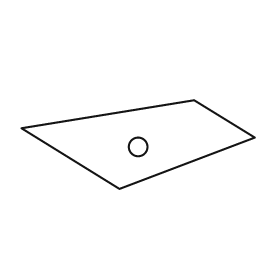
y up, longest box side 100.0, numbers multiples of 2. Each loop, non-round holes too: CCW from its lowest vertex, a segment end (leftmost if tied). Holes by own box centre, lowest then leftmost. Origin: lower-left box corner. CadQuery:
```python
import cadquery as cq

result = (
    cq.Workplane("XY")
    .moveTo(42.0, 0.0)
    .lineTo(100.0, 22.0)
    .lineTo(74.0, 38.0)
    .lineTo(0.0, 26.0)
    .close()
    .moveTo(50.0, 18.0)
    .circle(4.0)
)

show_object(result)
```